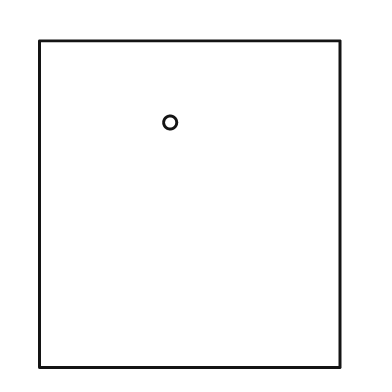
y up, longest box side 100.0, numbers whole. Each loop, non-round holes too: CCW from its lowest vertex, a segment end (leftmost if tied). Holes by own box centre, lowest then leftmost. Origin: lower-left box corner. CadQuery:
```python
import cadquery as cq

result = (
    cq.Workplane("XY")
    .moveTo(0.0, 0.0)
    .lineTo(92.0, 0.0)
    .lineTo(92.0, 100.0)
    .lineTo(0.0, 100.0)
    .close()
    .moveTo(40.0, 75.0)
    .circle(2.0)
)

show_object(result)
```